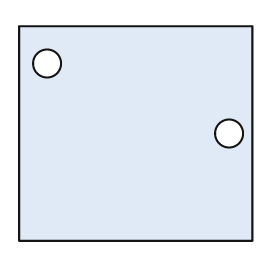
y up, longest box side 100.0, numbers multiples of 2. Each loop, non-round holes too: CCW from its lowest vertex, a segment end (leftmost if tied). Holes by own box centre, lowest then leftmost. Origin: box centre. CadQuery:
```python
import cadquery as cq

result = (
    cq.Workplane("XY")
    .moveTo(-50.0, -46.0)
    .lineTo(50.0, -46.0)
    .lineTo(50.0, 46.0)
    .lineTo(-50.0, 46.0)
    .close()
    .moveTo(40.0, 0.0)
    .circle(6.0)
    .moveTo(-38.0, 30.0)
    .circle(6.0)
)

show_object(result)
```